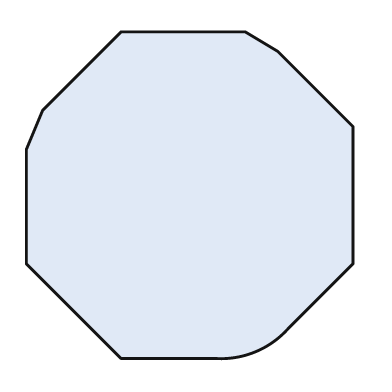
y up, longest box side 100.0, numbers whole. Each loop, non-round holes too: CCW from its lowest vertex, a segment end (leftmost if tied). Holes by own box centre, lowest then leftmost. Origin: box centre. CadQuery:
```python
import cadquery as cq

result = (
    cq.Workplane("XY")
    .moveTo(-21.0, -50.0)
    .lineTo(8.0, -50.0)
    .threePointArc((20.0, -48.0), (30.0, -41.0))
    .lineTo(50.0, -21.0)
    .lineTo(50.0, 21.0)
    .lineTo(27.0, 44.0)
    .lineTo(17.0, 50.0)
    .lineTo(-21.0, 50.0)
    .lineTo(-45.0, 26.0)
    .lineTo(-50.0, 14.0)
    .lineTo(-50.0, -21.0)
    .close()
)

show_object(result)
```